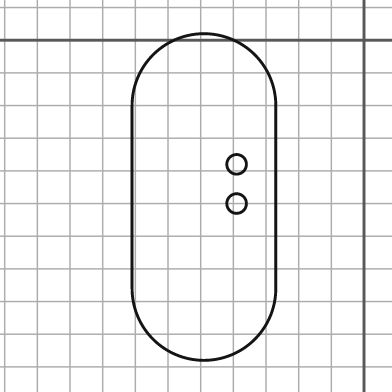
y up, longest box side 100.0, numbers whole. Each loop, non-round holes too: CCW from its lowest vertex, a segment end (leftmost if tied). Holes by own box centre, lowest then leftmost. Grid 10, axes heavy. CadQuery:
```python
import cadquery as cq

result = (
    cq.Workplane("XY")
    .moveTo(-71.0, -76.0)
    .threePointArc((-49.0, -98.0), (-27.0, -76.0))
    .lineTo(-27.0, -20.0)
    .threePointArc((-49.0, 2.0), (-71.0, -20.0))
    .close()
    .moveTo(-39.0, -50.0)
    .circle(3.0)
    .moveTo(-39.0, -38.0)
    .circle(3.0)
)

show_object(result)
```